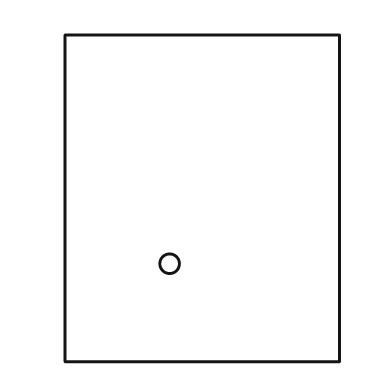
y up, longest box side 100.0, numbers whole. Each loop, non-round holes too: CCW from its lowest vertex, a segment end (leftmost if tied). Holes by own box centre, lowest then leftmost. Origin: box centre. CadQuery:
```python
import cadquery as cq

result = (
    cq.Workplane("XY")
    .moveTo(-42.0, -50.0)
    .lineTo(42.0, -50.0)
    .lineTo(42.0, 50.0)
    .lineTo(-42.0, 50.0)
    .close()
    .moveTo(-10.0, -20.0)
    .circle(3.0)
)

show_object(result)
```